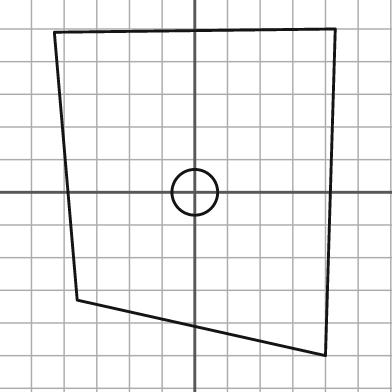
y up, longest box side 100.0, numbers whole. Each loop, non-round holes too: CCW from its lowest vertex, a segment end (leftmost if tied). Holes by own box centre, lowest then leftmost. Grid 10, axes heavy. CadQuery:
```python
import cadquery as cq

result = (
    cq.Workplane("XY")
    .moveTo(40.0, -50.0)
    .lineTo(43.0, 50.0)
    .lineTo(-43.0, 49.0)
    .lineTo(-36.0, -33.0)
    .close()
    .moveTo(0.0, 0.0)
    .circle(7.0)
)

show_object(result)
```